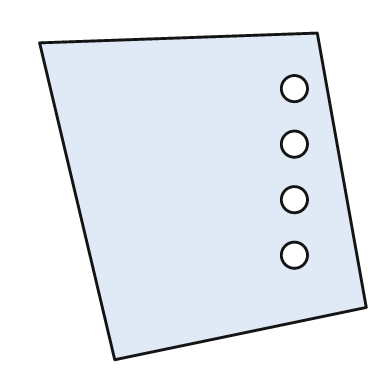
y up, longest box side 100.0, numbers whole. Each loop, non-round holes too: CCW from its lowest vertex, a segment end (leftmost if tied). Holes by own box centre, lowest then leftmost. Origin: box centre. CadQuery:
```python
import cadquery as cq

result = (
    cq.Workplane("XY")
    .moveTo(-27.0, -50.0)
    .lineTo(50.0, -34.0)
    .lineTo(35.0, 50.0)
    .lineTo(-50.0, 47.0)
    .close()
    .moveTo(28.0, -18.0)
    .circle(4.0)
    .moveTo(28.0, -1.0)
    .circle(4.0)
    .moveTo(28.0, 16.0)
    .circle(4.0)
    .moveTo(28.0, 33.0)
    .circle(4.0)
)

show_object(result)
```